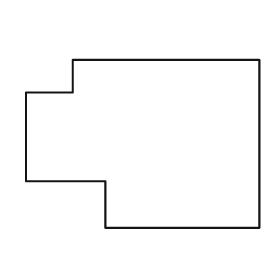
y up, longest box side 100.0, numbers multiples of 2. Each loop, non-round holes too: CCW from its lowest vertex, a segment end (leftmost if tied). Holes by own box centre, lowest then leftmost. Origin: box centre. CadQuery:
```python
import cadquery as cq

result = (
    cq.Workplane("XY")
    .moveTo(-16.0, -36.0)
    .lineTo(50.0, -36.0)
    .lineTo(50.0, 36.0)
    .lineTo(-30.0, 36.0)
    .lineTo(-30.0, 22.0)
    .lineTo(-50.0, 22.0)
    .lineTo(-50.0, -16.0)
    .lineTo(-16.0, -16.0)
    .close()
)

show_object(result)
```